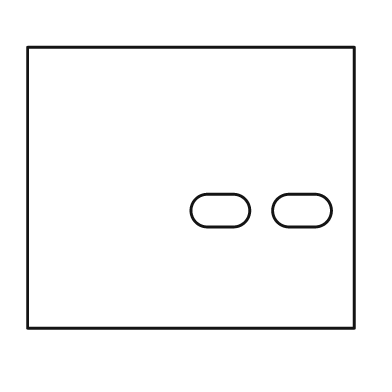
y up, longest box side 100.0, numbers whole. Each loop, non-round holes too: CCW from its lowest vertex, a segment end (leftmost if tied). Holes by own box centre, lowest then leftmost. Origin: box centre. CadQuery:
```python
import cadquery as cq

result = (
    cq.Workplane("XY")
    .moveTo(-50.0, -43.0)
    .lineTo(50.0, -43.0)
    .lineTo(50.0, 43.0)
    .lineTo(-50.0, 43.0)
    .close()
    .moveTo(5.0, -12.0)
    .lineTo(13.0, -12.0)
    .threePointArc((18.0, -7.0), (13.0, -2.0))
    .lineTo(5.0, -2.0)
    .threePointArc((0.0, -7.0), (5.0, -12.0))
    .close()
    .moveTo(30.0, -12.0)
    .lineTo(38.0, -12.0)
    .threePointArc((43.0, -7.0), (38.0, -2.0))
    .lineTo(30.0, -2.0)
    .threePointArc((25.0, -7.0), (30.0, -12.0))
    .close()
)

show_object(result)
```